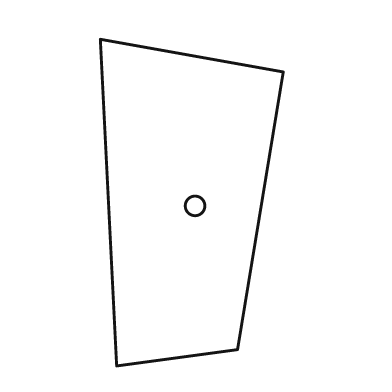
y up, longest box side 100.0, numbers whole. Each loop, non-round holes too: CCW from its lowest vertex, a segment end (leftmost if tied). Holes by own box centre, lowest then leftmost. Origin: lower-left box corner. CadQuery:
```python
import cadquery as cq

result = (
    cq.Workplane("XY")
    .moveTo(5.0, 0.0)
    .lineTo(42.0, 5.0)
    .lineTo(56.0, 90.0)
    .lineTo(0.0, 100.0)
    .close()
    .moveTo(29.0, 49.0)
    .circle(3.0)
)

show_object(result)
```